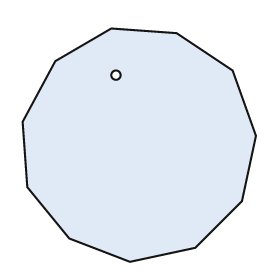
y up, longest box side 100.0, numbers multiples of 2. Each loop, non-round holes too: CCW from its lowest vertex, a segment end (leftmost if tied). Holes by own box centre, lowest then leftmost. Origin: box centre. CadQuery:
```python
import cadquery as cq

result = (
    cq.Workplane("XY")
    .moveTo(-4.0, -50.0)
    .lineTo(24.0, -44.0)
    .lineTo(44.0, -24.0)
    .lineTo(50.0, 4.0)
    .lineTo(40.0, 32.0)
    .lineTo(16.0, 48.0)
    .lineTo(-12.0, 50.0)
    .lineTo(-36.0, 36.0)
    .lineTo(-50.0, 10.0)
    .lineTo(-48.0, -18.0)
    .lineTo(-30.0, -40.0)
    .close()
    .moveTo(-10.0, 30.0)
    .circle(2.0)
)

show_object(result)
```